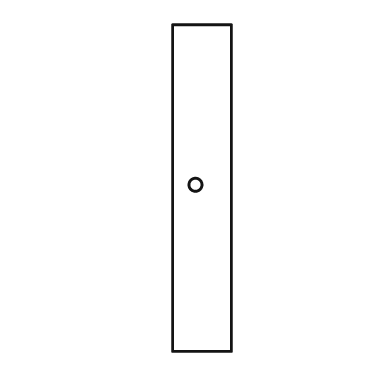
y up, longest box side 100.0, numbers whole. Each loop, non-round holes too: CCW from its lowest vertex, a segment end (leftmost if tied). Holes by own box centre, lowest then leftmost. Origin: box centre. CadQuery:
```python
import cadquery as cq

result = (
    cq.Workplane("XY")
    .moveTo(-9.0, -50.0)
    .lineTo(9.0, -50.0)
    .lineTo(9.0, 50.0)
    .lineTo(-9.0, 50.0)
    .close()
    .moveTo(-2.0, 1.0)
    .circle(2.0)
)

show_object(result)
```